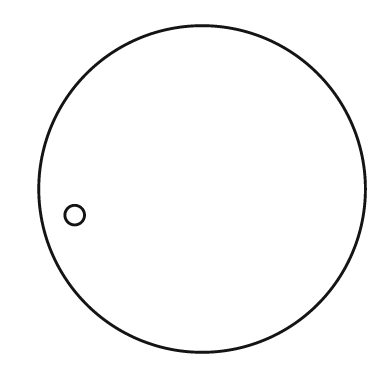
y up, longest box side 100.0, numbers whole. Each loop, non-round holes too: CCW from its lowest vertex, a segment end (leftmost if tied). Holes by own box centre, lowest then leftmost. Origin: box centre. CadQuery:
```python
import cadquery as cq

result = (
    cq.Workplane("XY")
    .moveTo(0.0, 0.0)
    .circle(50.0)
    .moveTo(-39.0, -8.0)
    .circle(3.0)
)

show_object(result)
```